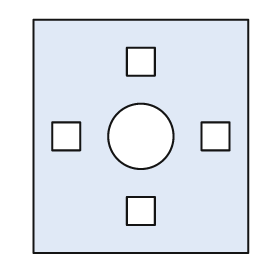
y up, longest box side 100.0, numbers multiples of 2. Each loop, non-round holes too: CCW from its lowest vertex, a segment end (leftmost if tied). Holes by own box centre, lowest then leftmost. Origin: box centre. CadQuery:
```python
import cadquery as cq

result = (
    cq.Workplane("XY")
    .moveTo(-46.0, -50.0)
    .lineTo(46.0, -50.0)
    .lineTo(46.0, 50.0)
    .lineTo(-46.0, 50.0)
    .close()
    .moveTo(-6.0, -38.0)
    .lineTo(6.0, -38.0)
    .lineTo(6.0, -26.0)
    .lineTo(-6.0, -26.0)
    .close()
    .moveTo(-38.0, -6.0)
    .lineTo(-26.0, -6.0)
    .lineTo(-26.0, 6.0)
    .lineTo(-38.0, 6.0)
    .close()
    .moveTo(0.0, 0.0)
    .circle(14.0)
    .moveTo(26.0, -6.0)
    .lineTo(38.0, -6.0)
    .lineTo(38.0, 6.0)
    .lineTo(26.0, 6.0)
    .close()
    .moveTo(-6.0, 26.0)
    .lineTo(6.0, 26.0)
    .lineTo(6.0, 38.0)
    .lineTo(-6.0, 38.0)
    .close()
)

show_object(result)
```